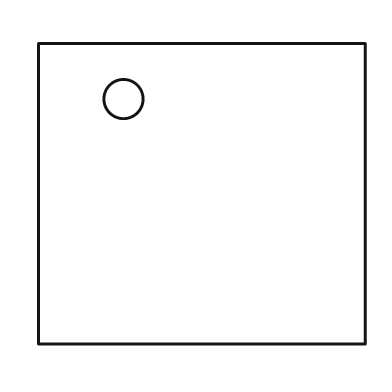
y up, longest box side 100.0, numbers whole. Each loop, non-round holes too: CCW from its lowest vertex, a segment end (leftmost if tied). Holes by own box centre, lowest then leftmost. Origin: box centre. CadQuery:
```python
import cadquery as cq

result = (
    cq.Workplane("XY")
    .moveTo(-50.0, -46.0)
    .lineTo(50.0, -46.0)
    .lineTo(50.0, 46.0)
    .lineTo(-50.0, 46.0)
    .close()
    .moveTo(-24.0, 29.0)
    .circle(6.0)
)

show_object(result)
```